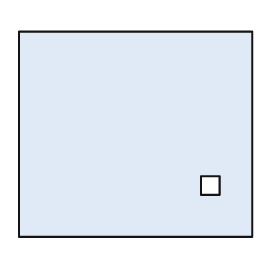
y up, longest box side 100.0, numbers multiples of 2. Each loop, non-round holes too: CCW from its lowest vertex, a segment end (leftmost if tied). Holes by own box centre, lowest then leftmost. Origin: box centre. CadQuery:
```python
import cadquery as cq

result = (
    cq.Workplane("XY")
    .moveTo(-50.0, -44.0)
    .lineTo(50.0, -44.0)
    .lineTo(50.0, 44.0)
    .lineTo(-50.0, 44.0)
    .close()
    .moveTo(28.0, -26.0)
    .lineTo(36.0, -26.0)
    .lineTo(36.0, -18.0)
    .lineTo(28.0, -18.0)
    .close()
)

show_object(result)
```